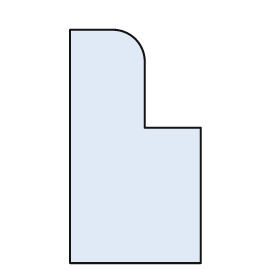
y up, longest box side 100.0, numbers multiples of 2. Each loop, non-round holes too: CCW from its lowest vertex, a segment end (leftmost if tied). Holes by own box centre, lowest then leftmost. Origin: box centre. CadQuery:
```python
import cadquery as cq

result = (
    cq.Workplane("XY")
    .moveTo(-28.0, -50.0)
    .lineTo(28.0, -50.0)
    .lineTo(28.0, 8.0)
    .lineTo(4.0, 8.0)
    .lineTo(4.0, 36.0)
    .threePointArc((0.0, 46.0), (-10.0, 50.0))
    .lineTo(-28.0, 50.0)
    .close()
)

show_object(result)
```